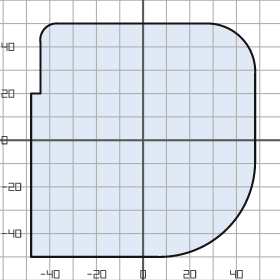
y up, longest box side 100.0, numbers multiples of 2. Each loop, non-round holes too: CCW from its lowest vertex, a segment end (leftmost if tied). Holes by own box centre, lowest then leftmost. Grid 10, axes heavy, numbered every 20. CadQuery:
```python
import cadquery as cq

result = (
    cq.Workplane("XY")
    .moveTo(-48.0, -50.0)
    .lineTo(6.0, -50.0)
    .threePointArc((36.0, -38.0), (48.0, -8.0))
    .lineTo(48.0, 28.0)
    .threePointArc((42.0, 44.0), (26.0, 50.0))
    .lineTo(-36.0, 50.0)
    .threePointArc((-42.0, 48.0), (-44.0, 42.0))
    .lineTo(-44.0, 20.0)
    .lineTo(-48.0, 20.0)
    .close()
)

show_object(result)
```